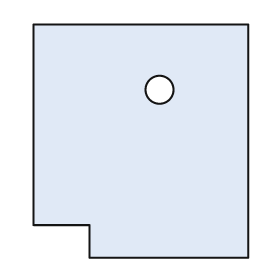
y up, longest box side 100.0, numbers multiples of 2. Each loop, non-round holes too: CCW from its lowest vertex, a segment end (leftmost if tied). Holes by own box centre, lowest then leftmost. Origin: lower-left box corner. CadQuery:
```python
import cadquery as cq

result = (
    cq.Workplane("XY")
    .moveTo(24.0, 0.0)
    .lineTo(92.0, 0.0)
    .lineTo(92.0, 100.0)
    .lineTo(0.0, 100.0)
    .lineTo(0.0, 14.0)
    .lineTo(24.0, 14.0)
    .close()
    .moveTo(54.0, 72.0)
    .circle(6.0)
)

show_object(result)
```